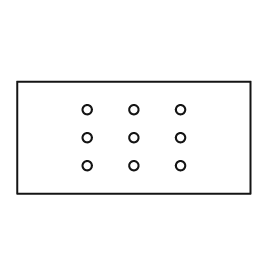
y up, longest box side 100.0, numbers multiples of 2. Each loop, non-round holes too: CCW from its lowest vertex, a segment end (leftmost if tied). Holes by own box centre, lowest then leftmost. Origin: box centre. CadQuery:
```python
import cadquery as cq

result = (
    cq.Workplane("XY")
    .moveTo(-50.0, -24.0)
    .lineTo(50.0, -24.0)
    .lineTo(50.0, 24.0)
    .lineTo(-50.0, 24.0)
    .close()
    .moveTo(-20.0, -12.0)
    .circle(2.0)
    .moveTo(0.0, -12.0)
    .circle(2.0)
    .moveTo(20.0, -12.0)
    .circle(2.0)
    .moveTo(-20.0, 0.0)
    .circle(2.0)
    .moveTo(0.0, 0.0)
    .circle(2.0)
    .moveTo(20.0, 0.0)
    .circle(2.0)
    .moveTo(-20.0, 12.0)
    .circle(2.0)
    .moveTo(0.0, 12.0)
    .circle(2.0)
    .moveTo(20.0, 12.0)
    .circle(2.0)
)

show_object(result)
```